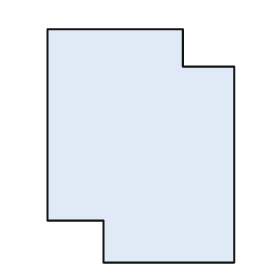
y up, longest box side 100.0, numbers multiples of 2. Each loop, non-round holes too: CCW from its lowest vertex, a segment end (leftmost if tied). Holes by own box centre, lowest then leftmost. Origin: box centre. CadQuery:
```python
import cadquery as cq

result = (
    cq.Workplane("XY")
    .moveTo(-16.0, -50.0)
    .lineTo(40.0, -50.0)
    .lineTo(40.0, 34.0)
    .lineTo(18.0, 34.0)
    .lineTo(18.0, 50.0)
    .lineTo(-40.0, 50.0)
    .lineTo(-40.0, -32.0)
    .lineTo(-16.0, -32.0)
    .close()
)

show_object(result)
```